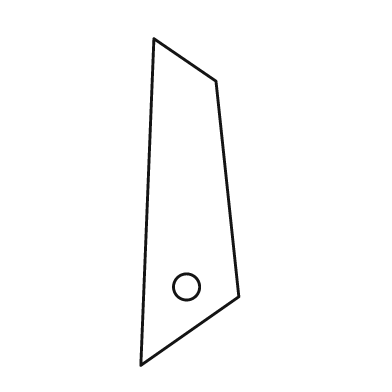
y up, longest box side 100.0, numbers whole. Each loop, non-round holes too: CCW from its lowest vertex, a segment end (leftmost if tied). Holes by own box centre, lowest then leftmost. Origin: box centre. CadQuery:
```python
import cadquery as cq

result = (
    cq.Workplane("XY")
    .moveTo(-15.0, -50.0)
    .lineTo(15.0, -29.0)
    .lineTo(8.0, 37.0)
    .lineTo(-11.0, 50.0)
    .close()
    .moveTo(-1.0, -26.0)
    .circle(4.0)
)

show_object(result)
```